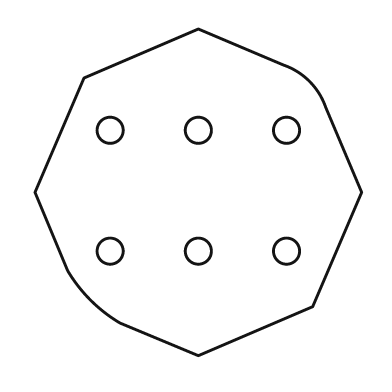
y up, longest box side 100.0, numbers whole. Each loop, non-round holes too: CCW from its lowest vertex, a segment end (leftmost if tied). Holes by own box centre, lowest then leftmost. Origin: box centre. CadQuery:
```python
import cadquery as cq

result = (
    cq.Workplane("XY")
    .moveTo(0.0, -50.0)
    .lineTo(35.0, -35.0)
    .lineTo(50.0, 0.0)
    .lineTo(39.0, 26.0)
    .threePointArc((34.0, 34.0), (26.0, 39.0))
    .lineTo(0.0, 50.0)
    .lineTo(-35.0, 35.0)
    .lineTo(-50.0, 0.0)
    .lineTo(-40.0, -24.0)
    .threePointArc((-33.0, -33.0), (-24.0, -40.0))
    .close()
    .moveTo(-27.0, -18.0)
    .circle(4.0)
    .moveTo(0.0, -18.0)
    .circle(4.0)
    .moveTo(27.0, -18.0)
    .circle(4.0)
    .moveTo(-27.0, 19.0)
    .circle(4.0)
    .moveTo(0.0, 19.0)
    .circle(4.0)
    .moveTo(27.0, 19.0)
    .circle(4.0)
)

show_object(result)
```